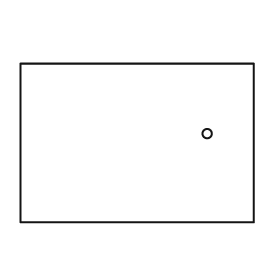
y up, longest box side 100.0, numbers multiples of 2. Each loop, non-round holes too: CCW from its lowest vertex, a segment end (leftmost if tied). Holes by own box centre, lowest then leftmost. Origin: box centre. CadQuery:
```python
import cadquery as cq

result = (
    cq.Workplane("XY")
    .moveTo(-50.0, -34.0)
    .lineTo(50.0, -34.0)
    .lineTo(50.0, 34.0)
    .lineTo(-50.0, 34.0)
    .close()
    .moveTo(30.0, 4.0)
    .circle(2.0)
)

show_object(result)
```